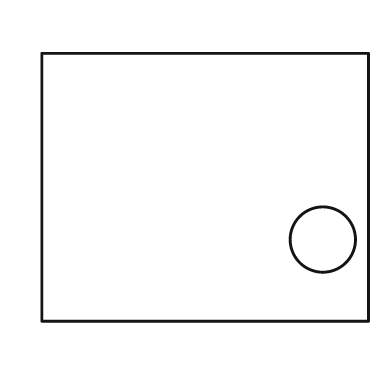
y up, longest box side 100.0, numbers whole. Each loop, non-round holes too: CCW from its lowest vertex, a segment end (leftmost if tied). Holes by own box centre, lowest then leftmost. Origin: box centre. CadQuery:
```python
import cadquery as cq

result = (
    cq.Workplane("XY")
    .moveTo(-50.0, -41.0)
    .lineTo(50.0, -41.0)
    .lineTo(50.0, 41.0)
    .lineTo(-50.0, 41.0)
    .close()
    .moveTo(36.0, -16.0)
    .circle(10.0)
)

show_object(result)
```